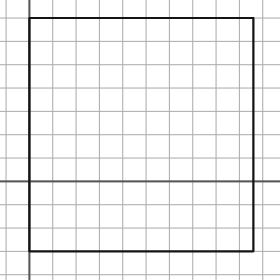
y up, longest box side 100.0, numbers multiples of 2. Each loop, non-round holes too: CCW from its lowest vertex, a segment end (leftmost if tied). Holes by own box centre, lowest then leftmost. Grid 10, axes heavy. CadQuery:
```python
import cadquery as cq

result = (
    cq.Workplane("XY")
    .moveTo(0.0, -30.0)
    .lineTo(96.0, -30.0)
    .lineTo(96.0, 70.0)
    .lineTo(0.0, 70.0)
    .close()
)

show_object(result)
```